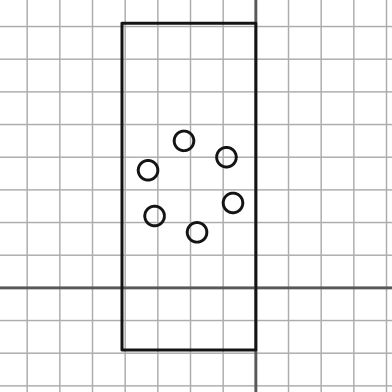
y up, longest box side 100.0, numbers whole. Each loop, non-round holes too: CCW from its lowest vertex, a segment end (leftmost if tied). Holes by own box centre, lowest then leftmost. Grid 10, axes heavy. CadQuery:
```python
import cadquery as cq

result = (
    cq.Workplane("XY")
    .moveTo(-41.0, -19.0)
    .lineTo(0.0, -19.0)
    .lineTo(0.0, 81.0)
    .lineTo(-41.0, 81.0)
    .close()
    .moveTo(-18.0, 17.0)
    .circle(3.0)
    .moveTo(-31.0, 22.0)
    .circle(3.0)
    .moveTo(-7.0, 26.0)
    .circle(3.0)
    .moveTo(-33.0, 36.0)
    .circle(3.0)
    .moveTo(-9.0, 40.0)
    .circle(3.0)
    .moveTo(-22.0, 45.0)
    .circle(3.0)
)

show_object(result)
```